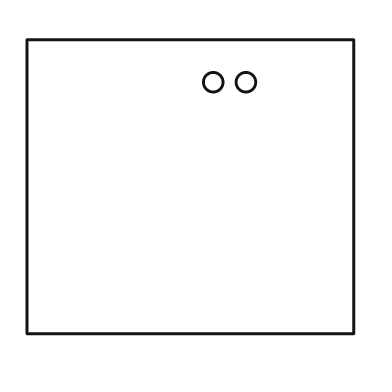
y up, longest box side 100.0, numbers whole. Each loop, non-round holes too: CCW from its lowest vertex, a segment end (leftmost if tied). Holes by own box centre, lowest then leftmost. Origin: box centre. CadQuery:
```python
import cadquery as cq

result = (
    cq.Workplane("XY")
    .moveTo(-50.0, -45.0)
    .lineTo(50.0, -45.0)
    .lineTo(50.0, 45.0)
    .lineTo(-50.0, 45.0)
    .close()
    .moveTo(7.0, 32.0)
    .circle(3.0)
    .moveTo(17.0, 32.0)
    .circle(3.0)
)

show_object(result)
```